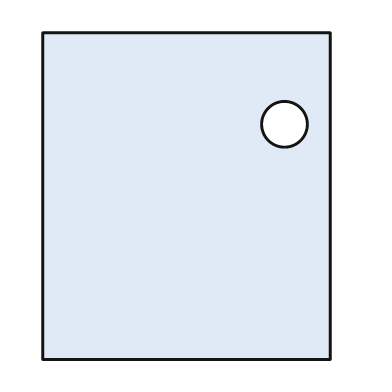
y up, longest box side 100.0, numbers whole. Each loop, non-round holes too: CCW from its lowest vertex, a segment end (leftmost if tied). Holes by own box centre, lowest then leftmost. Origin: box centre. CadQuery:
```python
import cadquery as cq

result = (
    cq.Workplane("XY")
    .moveTo(-44.0, -50.0)
    .lineTo(44.0, -50.0)
    .lineTo(44.0, 50.0)
    .lineTo(-44.0, 50.0)
    .close()
    .moveTo(30.0, 22.0)
    .circle(7.0)
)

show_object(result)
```